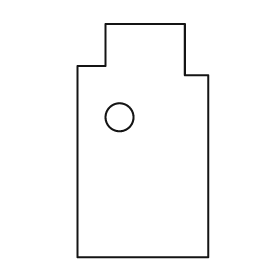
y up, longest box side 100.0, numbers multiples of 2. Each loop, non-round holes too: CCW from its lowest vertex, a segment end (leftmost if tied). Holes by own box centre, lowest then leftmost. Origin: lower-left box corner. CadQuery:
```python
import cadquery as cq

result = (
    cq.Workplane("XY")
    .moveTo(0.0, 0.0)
    .lineTo(56.0, 0.0)
    .lineTo(56.0, 78.0)
    .lineTo(46.0, 78.0)
    .lineTo(46.0, 100.0)
    .lineTo(12.0, 100.0)
    .lineTo(12.0, 82.0)
    .lineTo(0.0, 82.0)
    .close()
    .moveTo(18.0, 60.0)
    .circle(6.0)
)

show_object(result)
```